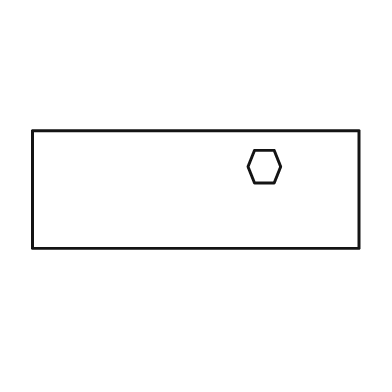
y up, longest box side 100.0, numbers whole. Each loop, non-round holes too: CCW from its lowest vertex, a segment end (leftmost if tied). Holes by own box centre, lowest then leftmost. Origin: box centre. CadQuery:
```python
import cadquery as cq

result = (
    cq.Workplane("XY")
    .moveTo(-50.0, -18.0)
    .lineTo(50.0, -18.0)
    .lineTo(50.0, 18.0)
    .lineTo(-50.0, 18.0)
    .close()
    .moveTo(18.0, 2.0)
    .lineTo(24.0, 2.0)
    .lineTo(26.0, 7.0)
    .lineTo(24.0, 12.0)
    .lineTo(18.0, 12.0)
    .lineTo(16.0, 7.0)
    .close()
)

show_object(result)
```